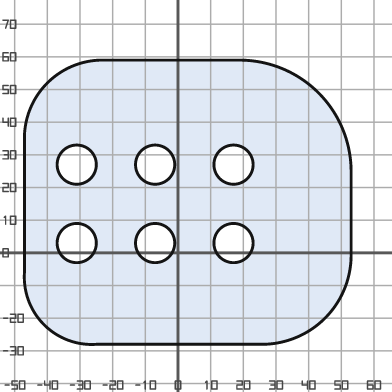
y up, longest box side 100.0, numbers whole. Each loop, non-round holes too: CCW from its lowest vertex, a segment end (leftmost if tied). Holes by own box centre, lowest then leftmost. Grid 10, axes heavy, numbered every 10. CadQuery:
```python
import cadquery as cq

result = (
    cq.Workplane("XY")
    .moveTo(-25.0, -28.0)
    .lineTo(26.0, -28.0)
    .threePointArc((45.0, -20.0), (53.0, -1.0))
    .lineTo(53.0, 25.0)
    .threePointArc((43.0, 49.0), (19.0, 59.0))
    .lineTo(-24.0, 59.0)
    .threePointArc((-40.0, 52.0), (-47.0, 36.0))
    .lineTo(-47.0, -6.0)
    .threePointArc((-41.0, -22.0), (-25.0, -28.0))
    .close()
    .moveTo(-31.0, 3.0)
    .circle(6.0)
    .moveTo(-7.0, 3.0)
    .circle(6.0)
    .moveTo(17.0, 3.0)
    .circle(6.0)
    .moveTo(-31.0, 27.0)
    .circle(6.0)
    .moveTo(-7.0, 27.0)
    .circle(6.0)
    .moveTo(17.0, 27.0)
    .circle(6.0)
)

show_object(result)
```